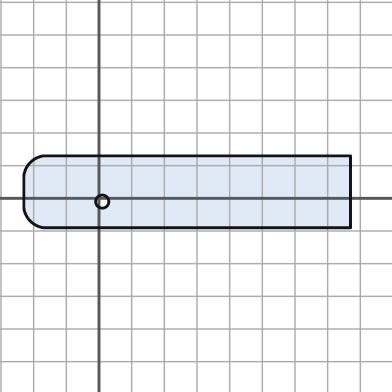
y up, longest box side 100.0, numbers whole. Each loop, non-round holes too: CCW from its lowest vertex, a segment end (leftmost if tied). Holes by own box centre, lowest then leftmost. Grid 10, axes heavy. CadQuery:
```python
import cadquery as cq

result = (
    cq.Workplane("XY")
    .moveTo(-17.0, -9.0)
    .lineTo(77.0, -9.0)
    .lineTo(77.0, 13.0)
    .lineTo(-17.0, 13.0)
    .threePointArc((-21.0, 11.0), (-23.0, 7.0))
    .lineTo(-23.0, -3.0)
    .threePointArc((-21.0, -7.0), (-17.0, -9.0))
    .close()
    .moveTo(1.0, -1.0)
    .circle(2.0)
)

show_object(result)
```